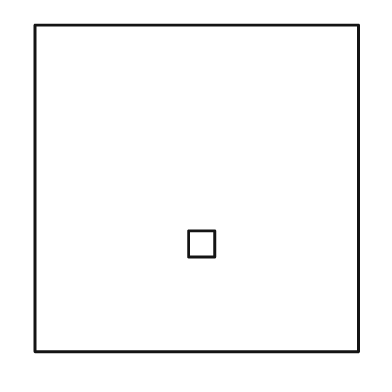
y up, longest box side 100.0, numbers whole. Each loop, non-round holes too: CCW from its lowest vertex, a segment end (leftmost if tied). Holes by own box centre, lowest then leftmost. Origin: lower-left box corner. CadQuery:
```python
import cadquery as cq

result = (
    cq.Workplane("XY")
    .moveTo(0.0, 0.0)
    .lineTo(99.0, 0.0)
    .lineTo(99.0, 100.0)
    .lineTo(0.0, 100.0)
    .close()
    .moveTo(47.0, 29.0)
    .lineTo(55.0, 29.0)
    .lineTo(55.0, 37.0)
    .lineTo(47.0, 37.0)
    .close()
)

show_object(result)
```